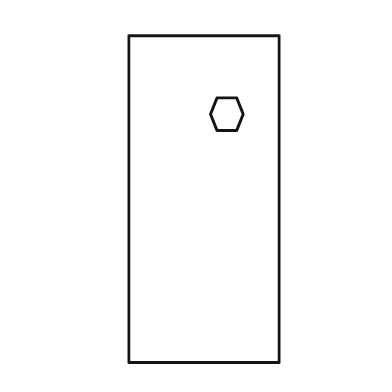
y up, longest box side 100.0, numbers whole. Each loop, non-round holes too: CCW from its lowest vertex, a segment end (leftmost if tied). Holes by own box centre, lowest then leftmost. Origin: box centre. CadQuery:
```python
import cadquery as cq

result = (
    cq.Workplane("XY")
    .moveTo(-23.0, -50.0)
    .lineTo(23.0, -50.0)
    .lineTo(23.0, 50.0)
    .lineTo(-23.0, 50.0)
    .close()
    .moveTo(4.0, 21.0)
    .lineTo(10.0, 21.0)
    .lineTo(12.0, 26.0)
    .lineTo(10.0, 31.0)
    .lineTo(4.0, 31.0)
    .lineTo(2.0, 26.0)
    .close()
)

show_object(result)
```